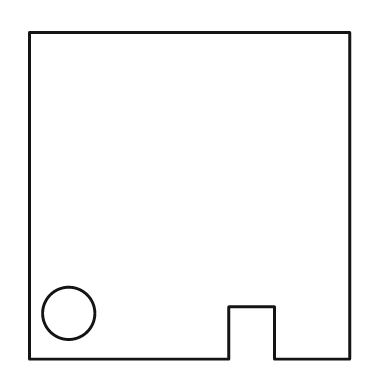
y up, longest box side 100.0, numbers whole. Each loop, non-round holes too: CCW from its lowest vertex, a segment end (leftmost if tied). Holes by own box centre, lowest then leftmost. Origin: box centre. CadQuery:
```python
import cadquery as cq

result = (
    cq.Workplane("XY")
    .moveTo(-49.0, -50.0)
    .lineTo(12.0, -50.0)
    .lineTo(12.0, -34.0)
    .lineTo(26.0, -34.0)
    .lineTo(26.0, -50.0)
    .lineTo(49.0, -50.0)
    .lineTo(49.0, 50.0)
    .lineTo(-49.0, 50.0)
    .close()
    .moveTo(-37.0, -36.0)
    .circle(8.0)
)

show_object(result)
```